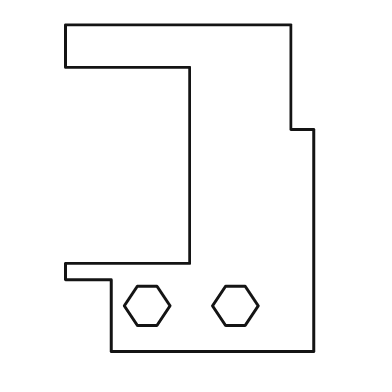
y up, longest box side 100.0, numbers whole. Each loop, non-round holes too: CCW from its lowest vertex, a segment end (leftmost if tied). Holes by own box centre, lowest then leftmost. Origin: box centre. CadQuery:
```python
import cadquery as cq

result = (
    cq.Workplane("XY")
    .moveTo(-24.0, -50.0)
    .lineTo(38.0, -50.0)
    .lineTo(38.0, 18.0)
    .lineTo(31.0, 18.0)
    .lineTo(31.0, 50.0)
    .lineTo(-38.0, 50.0)
    .lineTo(-38.0, 37.0)
    .lineTo(0.0, 37.0)
    .lineTo(0.0, -23.0)
    .lineTo(-38.0, -23.0)
    .lineTo(-38.0, -28.0)
    .lineTo(-24.0, -28.0)
    .close()
    .moveTo(-16.0, -42.0)
    .lineTo(-10.0, -42.0)
    .lineTo(-6.0, -36.0)
    .lineTo(-10.0, -30.0)
    .lineTo(-16.0, -30.0)
    .lineTo(-20.0, -36.0)
    .close()
    .moveTo(11.0, -42.0)
    .lineTo(17.0, -42.0)
    .lineTo(21.0, -36.0)
    .lineTo(17.0, -30.0)
    .lineTo(11.0, -30.0)
    .lineTo(7.0, -36.0)
    .close()
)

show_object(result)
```